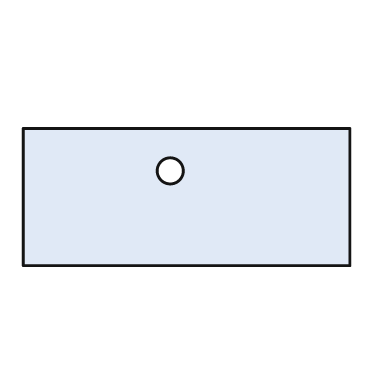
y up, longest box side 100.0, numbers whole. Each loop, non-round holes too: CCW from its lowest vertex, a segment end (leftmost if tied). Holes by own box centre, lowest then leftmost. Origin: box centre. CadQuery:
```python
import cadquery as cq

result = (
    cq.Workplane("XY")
    .moveTo(-50.0, -21.0)
    .lineTo(50.0, -21.0)
    .lineTo(50.0, 21.0)
    .lineTo(-50.0, 21.0)
    .close()
    .moveTo(-5.0, 8.0)
    .circle(4.0)
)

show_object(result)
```